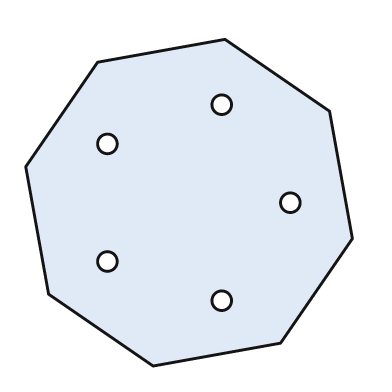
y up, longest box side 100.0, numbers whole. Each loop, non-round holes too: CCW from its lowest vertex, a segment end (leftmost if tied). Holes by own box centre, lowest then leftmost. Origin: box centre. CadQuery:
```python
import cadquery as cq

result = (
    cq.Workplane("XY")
    .moveTo(-11.0, -50.0)
    .lineTo(28.0, -43.0)
    .lineTo(50.0, -11.0)
    .lineTo(43.0, 28.0)
    .lineTo(11.0, 50.0)
    .lineTo(-28.0, 43.0)
    .lineTo(-50.0, 11.0)
    .lineTo(-43.0, -28.0)
    .close()
    .moveTo(10.0, -30.0)
    .circle(3.0)
    .moveTo(-25.0, -18.0)
    .circle(3.0)
    .moveTo(31.0, 0.0)
    .circle(3.0)
    .moveTo(-25.0, 18.0)
    .circle(3.0)
    .moveTo(10.0, 30.0)
    .circle(3.0)
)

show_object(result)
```